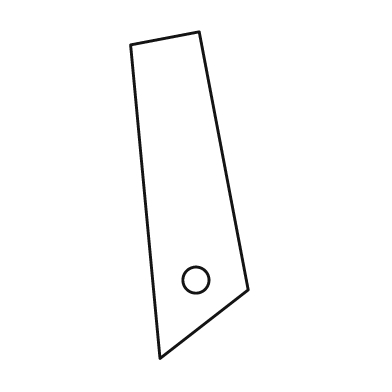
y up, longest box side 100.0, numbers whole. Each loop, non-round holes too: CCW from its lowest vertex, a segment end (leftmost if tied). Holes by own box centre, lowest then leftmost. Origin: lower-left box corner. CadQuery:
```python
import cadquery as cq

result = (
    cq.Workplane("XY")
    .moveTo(9.0, 0.0)
    .lineTo(36.0, 21.0)
    .lineTo(21.0, 100.0)
    .lineTo(0.0, 96.0)
    .close()
    .moveTo(20.0, 24.0)
    .circle(4.0)
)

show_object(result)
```